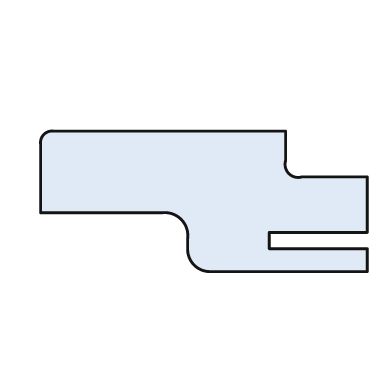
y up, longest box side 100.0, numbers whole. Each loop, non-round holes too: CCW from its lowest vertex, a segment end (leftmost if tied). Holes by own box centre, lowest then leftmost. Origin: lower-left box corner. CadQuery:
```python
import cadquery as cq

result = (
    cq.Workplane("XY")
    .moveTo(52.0, 0.0)
    .lineTo(100.0, 0.0)
    .lineTo(100.0, 7.0)
    .lineTo(70.0, 7.0)
    .lineTo(70.0, 12.0)
    .lineTo(100.0, 12.0)
    .lineTo(100.0, 29.0)
    .lineTo(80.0, 29.0)
    .threePointArc((76.0, 30.0), (75.0, 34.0))
    .lineTo(75.0, 43.0)
    .lineTo(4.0, 43.0)
    .threePointArc((1.0, 42.0), (0.0, 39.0))
    .lineTo(0.0, 18.0)
    .lineTo(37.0, 18.0)
    .threePointArc((43.0, 16.0), (45.0, 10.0))
    .lineTo(45.0, 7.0)
    .threePointArc((47.0, 2.0), (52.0, 0.0))
    .close()
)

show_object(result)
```